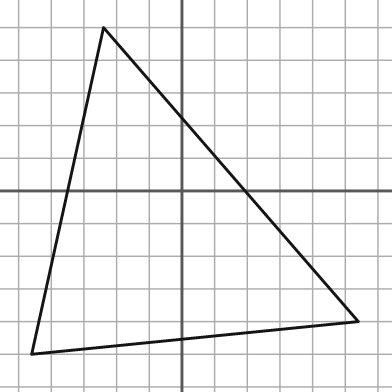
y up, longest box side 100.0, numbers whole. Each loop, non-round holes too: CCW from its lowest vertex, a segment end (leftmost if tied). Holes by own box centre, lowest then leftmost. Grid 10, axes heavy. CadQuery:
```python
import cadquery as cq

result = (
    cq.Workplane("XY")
    .moveTo(-46.0, -50.0)
    .lineTo(54.0, -40.0)
    .lineTo(-24.0, 50.0)
    .close()
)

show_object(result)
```